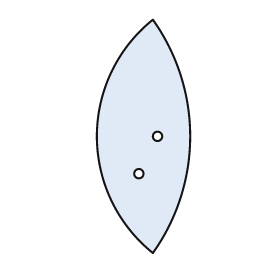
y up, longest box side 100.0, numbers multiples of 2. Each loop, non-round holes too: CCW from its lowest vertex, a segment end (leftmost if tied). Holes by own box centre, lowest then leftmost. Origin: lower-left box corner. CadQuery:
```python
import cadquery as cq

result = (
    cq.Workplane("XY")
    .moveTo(24.0, 0.0)
    .threePointArc((40.0, 50.0), (24.0, 100.0))
    .threePointArc((0.0, 50.0), (24.0, 0.0))
    .close()
    .moveTo(18.0, 34.0)
    .circle(2.0)
    .moveTo(26.0, 50.0)
    .circle(2.0)
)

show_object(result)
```